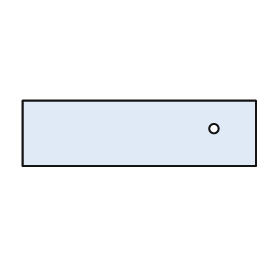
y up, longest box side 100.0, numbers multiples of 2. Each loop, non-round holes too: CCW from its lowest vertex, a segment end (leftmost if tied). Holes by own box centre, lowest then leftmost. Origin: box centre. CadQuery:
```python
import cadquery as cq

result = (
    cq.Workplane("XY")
    .moveTo(-50.0, -14.0)
    .lineTo(50.0, -14.0)
    .lineTo(50.0, 14.0)
    .lineTo(-50.0, 14.0)
    .close()
    .moveTo(32.0, 2.0)
    .circle(2.0)
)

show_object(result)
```